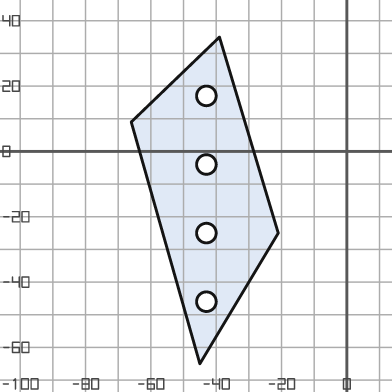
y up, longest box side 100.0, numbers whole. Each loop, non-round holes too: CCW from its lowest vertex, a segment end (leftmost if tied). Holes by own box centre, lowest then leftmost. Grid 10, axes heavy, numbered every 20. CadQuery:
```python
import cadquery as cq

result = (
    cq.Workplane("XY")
    .moveTo(-45.0, -65.0)
    .lineTo(-21.0, -25.0)
    .lineTo(-39.0, 35.0)
    .lineTo(-66.0, 9.0)
    .close()
    .moveTo(-43.0, -46.0)
    .circle(3.0)
    .moveTo(-43.0, -25.0)
    .circle(3.0)
    .moveTo(-43.0, -4.0)
    .circle(3.0)
    .moveTo(-43.0, 17.0)
    .circle(3.0)
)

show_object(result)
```